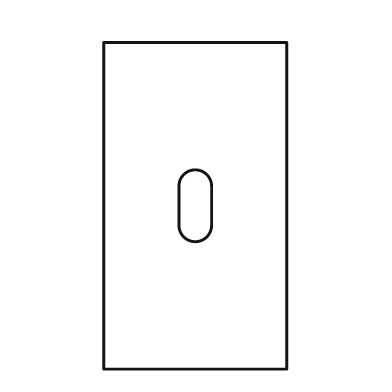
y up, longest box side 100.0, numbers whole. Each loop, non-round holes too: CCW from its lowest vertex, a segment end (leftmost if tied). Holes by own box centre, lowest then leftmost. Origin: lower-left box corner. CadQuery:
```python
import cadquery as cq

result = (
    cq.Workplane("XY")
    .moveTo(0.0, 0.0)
    .lineTo(56.0, 0.0)
    .lineTo(56.0, 100.0)
    .lineTo(0.0, 100.0)
    .close()
    .moveTo(23.0, 44.0)
    .threePointArc((28.0, 39.0), (33.0, 44.0))
    .lineTo(33.0, 56.0)
    .threePointArc((28.0, 61.0), (23.0, 56.0))
    .close()
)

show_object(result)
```